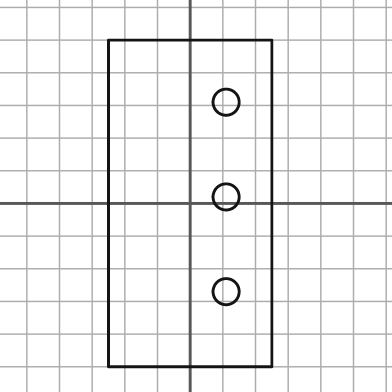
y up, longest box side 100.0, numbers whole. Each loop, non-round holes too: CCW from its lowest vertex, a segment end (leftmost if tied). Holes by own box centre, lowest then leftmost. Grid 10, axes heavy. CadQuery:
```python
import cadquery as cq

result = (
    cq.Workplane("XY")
    .moveTo(-25.0, -50.0)
    .lineTo(25.0, -50.0)
    .lineTo(25.0, 50.0)
    .lineTo(-25.0, 50.0)
    .close()
    .moveTo(11.0, -27.0)
    .circle(4.0)
    .moveTo(11.0, 2.0)
    .circle(4.0)
    .moveTo(11.0, 31.0)
    .circle(4.0)
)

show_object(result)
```